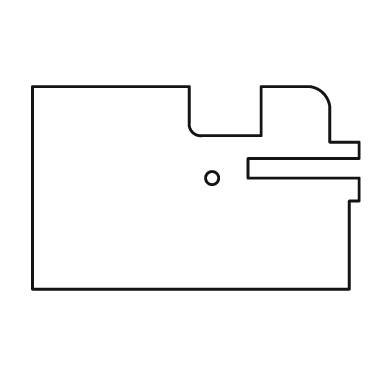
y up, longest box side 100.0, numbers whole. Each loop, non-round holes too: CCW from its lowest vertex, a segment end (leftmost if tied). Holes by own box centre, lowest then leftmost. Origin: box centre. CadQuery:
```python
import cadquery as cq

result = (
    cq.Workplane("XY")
    .moveTo(-50.0, -31.0)
    .lineTo(47.0, -31.0)
    .lineTo(47.0, -4.0)
    .lineTo(50.0, -4.0)
    .lineTo(50.0, 3.0)
    .lineTo(16.0, 3.0)
    .lineTo(16.0, 9.0)
    .lineTo(50.0, 9.0)
    .lineTo(50.0, 14.0)
    .lineTo(41.0, 14.0)
    .lineTo(41.0, 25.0)
    .threePointArc((39.0, 29.0), (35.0, 31.0))
    .lineTo(20.0, 31.0)
    .lineTo(20.0, 16.0)
    .lineTo(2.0, 16.0)
    .threePointArc((-1.0, 17.0), (-2.0, 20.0))
    .lineTo(-2.0, 31.0)
    .lineTo(-50.0, 31.0)
    .close()
    .moveTo(5.0, 3.0)
    .circle(2.0)
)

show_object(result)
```